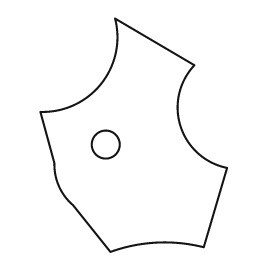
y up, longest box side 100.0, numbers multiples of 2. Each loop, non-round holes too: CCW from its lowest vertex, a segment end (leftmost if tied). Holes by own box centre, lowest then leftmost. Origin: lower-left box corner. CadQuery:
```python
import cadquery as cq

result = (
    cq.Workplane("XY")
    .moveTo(30.0, 0.0)
    .threePointArc((50.0, 4.0), (70.0, 2.0))
    .lineTo(80.0, 36.0)
    .threePointArc((60.0, 54.0), (66.0, 80.0))
    .lineTo(32.0, 100.0)
    .threePointArc((26.0, 72.0), (0.0, 60.0))
    .lineTo(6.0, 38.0)
    .threePointArc((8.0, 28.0), (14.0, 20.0))
    .close()
    .moveTo(28.0, 46.0)
    .circle(6.0)
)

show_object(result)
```